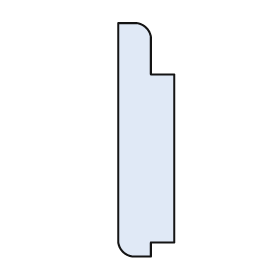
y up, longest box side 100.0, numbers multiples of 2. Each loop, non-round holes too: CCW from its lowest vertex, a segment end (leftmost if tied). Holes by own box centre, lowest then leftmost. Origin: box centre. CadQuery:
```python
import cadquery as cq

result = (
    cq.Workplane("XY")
    .moveTo(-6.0, -50.0)
    .lineTo(2.0, -50.0)
    .lineTo(2.0, -44.0)
    .lineTo(12.0, -44.0)
    .lineTo(12.0, 28.0)
    .lineTo(2.0, 28.0)
    .lineTo(2.0, 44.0)
    .threePointArc((0.0, 48.0), (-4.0, 50.0))
    .lineTo(-12.0, 50.0)
    .lineTo(-12.0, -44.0)
    .threePointArc((-10.0, -48.0), (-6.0, -50.0))
    .close()
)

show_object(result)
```